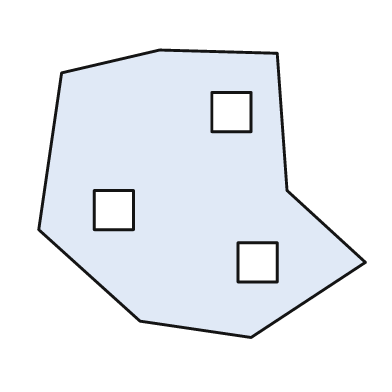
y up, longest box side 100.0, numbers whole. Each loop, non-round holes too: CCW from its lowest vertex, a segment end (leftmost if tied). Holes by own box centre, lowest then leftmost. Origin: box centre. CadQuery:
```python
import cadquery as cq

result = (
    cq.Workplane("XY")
    .moveTo(15.0, -44.0)
    .lineTo(50.0, -21.0)
    .lineTo(26.0, 1.0)
    .lineTo(23.0, 43.0)
    .lineTo(-13.0, 44.0)
    .lineTo(-43.0, 37.0)
    .lineTo(-50.0, -11.0)
    .lineTo(-19.0, -39.0)
    .close()
    .moveTo(11.0, -27.0)
    .lineTo(23.0, -27.0)
    .lineTo(23.0, -15.0)
    .lineTo(11.0, -15.0)
    .close()
    .moveTo(-33.0, -11.0)
    .lineTo(-21.0, -11.0)
    .lineTo(-21.0, 1.0)
    .lineTo(-33.0, 1.0)
    .close()
    .moveTo(3.0, 19.0)
    .lineTo(15.0, 19.0)
    .lineTo(15.0, 31.0)
    .lineTo(3.0, 31.0)
    .close()
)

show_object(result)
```